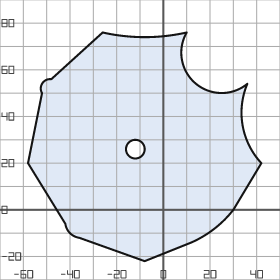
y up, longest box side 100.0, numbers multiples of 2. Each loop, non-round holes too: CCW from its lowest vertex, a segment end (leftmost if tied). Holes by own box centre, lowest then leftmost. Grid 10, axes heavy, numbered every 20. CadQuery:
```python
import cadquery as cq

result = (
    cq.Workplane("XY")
    .moveTo(-8.0, -22.0)
    .lineTo(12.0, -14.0)
    .threePointArc((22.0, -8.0), (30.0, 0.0))
    .lineTo(42.0, 20.0)
    .threePointArc((34.0, 36.0), (36.0, 54.0))
    .threePointArc((14.0, 54.0), (10.0, 76.0))
    .threePointArc((-8.0, 74.0), (-26.0, 76.0))
    .lineTo(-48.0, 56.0)
    .threePointArc((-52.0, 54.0), (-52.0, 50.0))
    .lineTo(-58.0, 20.0)
    .lineTo(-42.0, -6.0)
    .threePointArc((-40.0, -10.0), (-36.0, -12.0))
    .close()
    .moveTo(-12.0, 26.0)
    .circle(4.0)
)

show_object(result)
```